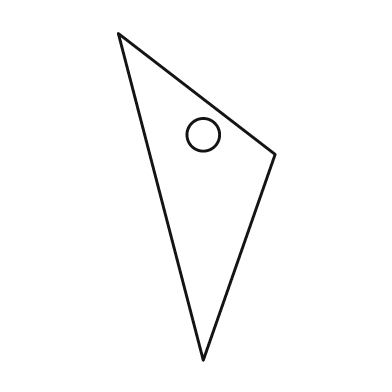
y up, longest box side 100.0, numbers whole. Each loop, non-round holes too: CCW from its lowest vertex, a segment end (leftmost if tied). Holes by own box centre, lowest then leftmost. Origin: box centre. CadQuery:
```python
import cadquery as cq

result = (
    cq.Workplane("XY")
    .moveTo(2.0, -50.0)
    .lineTo(24.0, 13.0)
    .lineTo(-24.0, 50.0)
    .close()
    .moveTo(2.0, 19.0)
    .circle(5.0)
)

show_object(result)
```